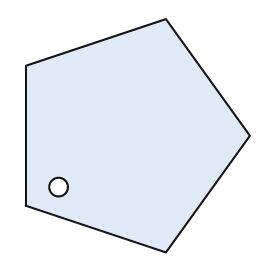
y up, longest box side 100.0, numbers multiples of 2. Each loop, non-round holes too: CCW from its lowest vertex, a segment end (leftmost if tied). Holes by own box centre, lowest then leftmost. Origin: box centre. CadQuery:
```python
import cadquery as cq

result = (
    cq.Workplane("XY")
    .moveTo(12.0, -50.0)
    .lineTo(48.0, 0.0)
    .lineTo(12.0, 50.0)
    .lineTo(-48.0, 30.0)
    .lineTo(-48.0, -30.0)
    .close()
    .moveTo(-34.0, -22.0)
    .circle(4.0)
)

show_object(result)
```